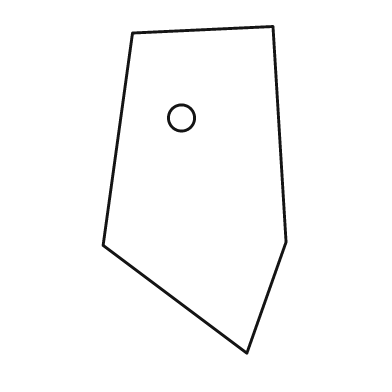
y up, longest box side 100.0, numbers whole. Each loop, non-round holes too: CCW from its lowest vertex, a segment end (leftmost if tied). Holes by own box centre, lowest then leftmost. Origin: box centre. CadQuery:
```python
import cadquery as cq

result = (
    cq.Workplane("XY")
    .moveTo(16.0, -50.0)
    .lineTo(28.0, -16.0)
    .lineTo(24.0, 50.0)
    .lineTo(-19.0, 48.0)
    .lineTo(-28.0, -17.0)
    .close()
    .moveTo(-4.0, 22.0)
    .circle(4.0)
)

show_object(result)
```